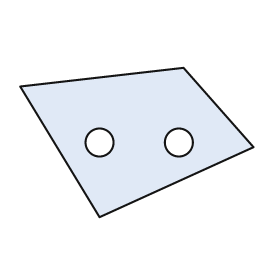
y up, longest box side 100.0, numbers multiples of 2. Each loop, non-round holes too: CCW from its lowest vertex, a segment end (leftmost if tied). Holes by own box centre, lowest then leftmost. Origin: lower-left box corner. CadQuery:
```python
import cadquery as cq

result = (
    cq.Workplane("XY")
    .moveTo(34.0, 0.0)
    .lineTo(100.0, 30.0)
    .lineTo(70.0, 64.0)
    .lineTo(0.0, 56.0)
    .close()
    .moveTo(34.0, 32.0)
    .circle(6.0)
    .moveTo(68.0, 32.0)
    .circle(6.0)
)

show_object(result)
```